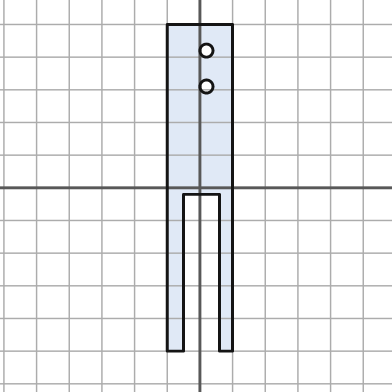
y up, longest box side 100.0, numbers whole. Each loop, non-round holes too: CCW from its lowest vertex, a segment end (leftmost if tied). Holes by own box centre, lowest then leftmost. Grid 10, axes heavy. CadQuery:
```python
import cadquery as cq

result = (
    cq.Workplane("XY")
    .moveTo(-10.0, -50.0)
    .lineTo(-5.0, -50.0)
    .lineTo(-5.0, -2.0)
    .lineTo(6.0, -2.0)
    .lineTo(6.0, -50.0)
    .lineTo(10.0, -50.0)
    .lineTo(10.0, 50.0)
    .lineTo(-10.0, 50.0)
    .close()
    .moveTo(2.0, 31.0)
    .circle(2.0)
    .moveTo(2.0, 42.0)
    .circle(2.0)
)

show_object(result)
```